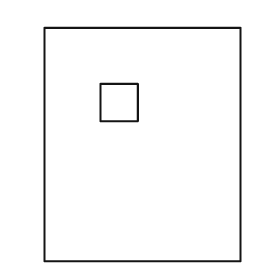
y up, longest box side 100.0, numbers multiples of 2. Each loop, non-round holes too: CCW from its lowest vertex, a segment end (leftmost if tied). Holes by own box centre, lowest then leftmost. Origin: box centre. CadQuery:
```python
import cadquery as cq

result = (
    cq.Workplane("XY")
    .moveTo(-42.0, -50.0)
    .lineTo(42.0, -50.0)
    .lineTo(42.0, 50.0)
    .lineTo(-42.0, 50.0)
    .close()
    .moveTo(-18.0, 10.0)
    .lineTo(-2.0, 10.0)
    .lineTo(-2.0, 26.0)
    .lineTo(-18.0, 26.0)
    .close()
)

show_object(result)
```